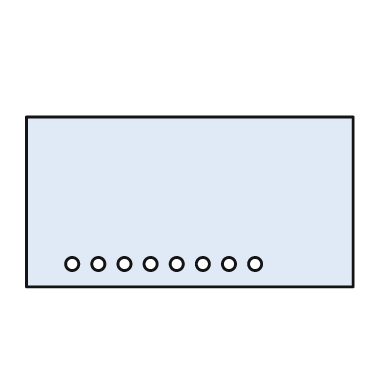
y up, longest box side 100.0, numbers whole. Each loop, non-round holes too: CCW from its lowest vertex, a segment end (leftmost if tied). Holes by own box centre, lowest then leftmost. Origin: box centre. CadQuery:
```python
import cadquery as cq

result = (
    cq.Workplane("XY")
    .moveTo(-50.0, -26.0)
    .lineTo(50.0, -26.0)
    .lineTo(50.0, 26.0)
    .lineTo(-50.0, 26.0)
    .close()
    .moveTo(-36.0, -19.0)
    .circle(2.0)
    .moveTo(-28.0, -19.0)
    .circle(2.0)
    .moveTo(-20.0, -19.0)
    .circle(2.0)
    .moveTo(-12.0, -19.0)
    .circle(2.0)
    .moveTo(-4.0, -19.0)
    .circle(2.0)
    .moveTo(4.0, -19.0)
    .circle(2.0)
    .moveTo(12.0, -19.0)
    .circle(2.0)
    .moveTo(20.0, -19.0)
    .circle(2.0)
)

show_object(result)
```